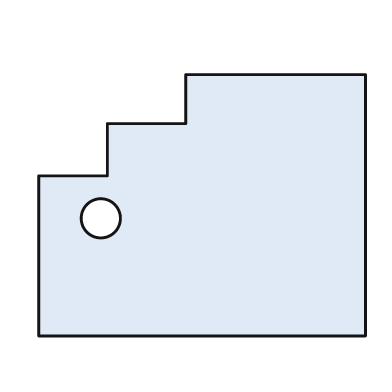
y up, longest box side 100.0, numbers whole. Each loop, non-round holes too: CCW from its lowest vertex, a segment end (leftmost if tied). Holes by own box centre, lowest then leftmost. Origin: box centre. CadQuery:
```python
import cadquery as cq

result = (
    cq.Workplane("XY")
    .moveTo(-50.0, -40.0)
    .lineTo(50.0, -40.0)
    .lineTo(50.0, 40.0)
    .lineTo(-5.0, 40.0)
    .lineTo(-5.0, 25.0)
    .lineTo(-29.0, 25.0)
    .lineTo(-29.0, 9.0)
    .lineTo(-50.0, 9.0)
    .close()
    .moveTo(-31.0, -4.0)
    .circle(6.0)
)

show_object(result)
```